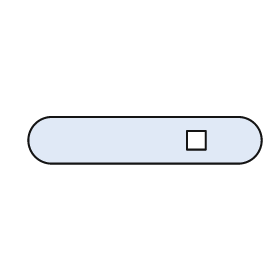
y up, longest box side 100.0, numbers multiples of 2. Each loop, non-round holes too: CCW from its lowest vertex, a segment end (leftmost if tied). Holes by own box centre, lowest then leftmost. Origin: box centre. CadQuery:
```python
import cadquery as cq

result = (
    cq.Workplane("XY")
    .moveTo(-40.0, -10.0)
    .lineTo(40.0, -10.0)
    .threePointArc((50.0, 0.0), (40.0, 10.0))
    .lineTo(-40.0, 10.0)
    .threePointArc((-50.0, 0.0), (-40.0, -10.0))
    .close()
    .moveTo(18.0, -4.0)
    .lineTo(26.0, -4.0)
    .lineTo(26.0, 4.0)
    .lineTo(18.0, 4.0)
    .close()
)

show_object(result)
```